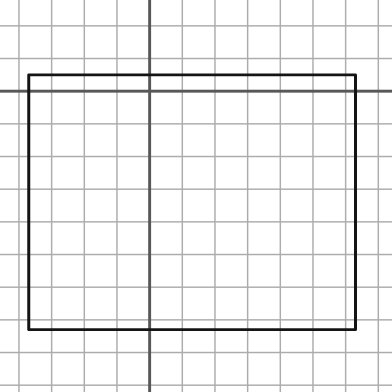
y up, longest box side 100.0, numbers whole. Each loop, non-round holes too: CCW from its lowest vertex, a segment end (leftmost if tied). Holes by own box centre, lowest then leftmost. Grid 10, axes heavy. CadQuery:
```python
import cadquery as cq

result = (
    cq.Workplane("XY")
    .moveTo(-37.0, -73.0)
    .lineTo(63.0, -73.0)
    .lineTo(63.0, 5.0)
    .lineTo(-37.0, 5.0)
    .close()
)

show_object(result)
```